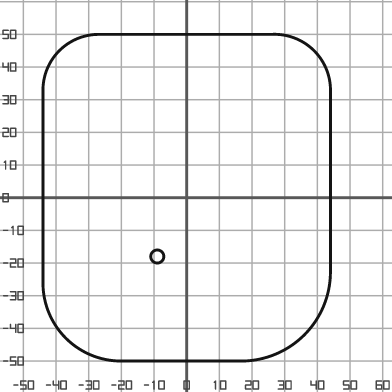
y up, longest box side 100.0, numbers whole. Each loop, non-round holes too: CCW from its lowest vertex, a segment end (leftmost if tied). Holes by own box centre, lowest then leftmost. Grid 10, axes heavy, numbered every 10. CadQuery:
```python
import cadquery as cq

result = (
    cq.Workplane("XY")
    .moveTo(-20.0, -50.0)
    .lineTo(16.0, -50.0)
    .threePointArc((36.0, -42.0), (44.0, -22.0))
    .lineTo(44.0, 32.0)
    .threePointArc((39.0, 45.0), (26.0, 50.0))
    .lineTo(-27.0, 50.0)
    .threePointArc((-39.0, 45.0), (-44.0, 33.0))
    .lineTo(-44.0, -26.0)
    .threePointArc((-37.0, -43.0), (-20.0, -50.0))
    .close()
    .moveTo(-9.0, -18.0)
    .circle(2.0)
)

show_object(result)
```